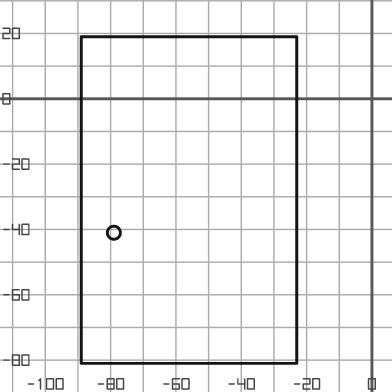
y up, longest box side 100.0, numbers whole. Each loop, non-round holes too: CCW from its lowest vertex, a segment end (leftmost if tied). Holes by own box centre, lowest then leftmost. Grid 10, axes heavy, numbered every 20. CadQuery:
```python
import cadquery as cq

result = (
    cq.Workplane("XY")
    .moveTo(-89.0, -81.0)
    .lineTo(-23.0, -81.0)
    .lineTo(-23.0, 19.0)
    .lineTo(-89.0, 19.0)
    .close()
    .moveTo(-79.0, -41.0)
    .circle(2.0)
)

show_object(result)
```